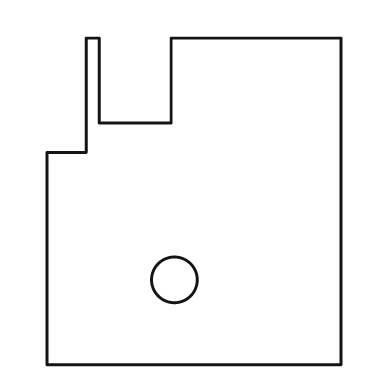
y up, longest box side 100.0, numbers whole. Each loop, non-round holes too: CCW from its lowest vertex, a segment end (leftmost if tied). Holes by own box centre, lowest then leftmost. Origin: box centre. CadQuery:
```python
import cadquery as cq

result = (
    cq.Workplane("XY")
    .moveTo(-45.0, -50.0)
    .lineTo(45.0, -50.0)
    .lineTo(45.0, 50.0)
    .lineTo(-7.0, 50.0)
    .lineTo(-7.0, 24.0)
    .lineTo(-29.0, 24.0)
    .lineTo(-29.0, 50.0)
    .lineTo(-33.0, 50.0)
    .lineTo(-33.0, 15.0)
    .lineTo(-45.0, 15.0)
    .close()
    .moveTo(-6.0, -24.0)
    .circle(7.0)
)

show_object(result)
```